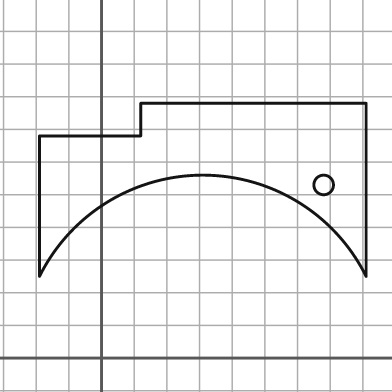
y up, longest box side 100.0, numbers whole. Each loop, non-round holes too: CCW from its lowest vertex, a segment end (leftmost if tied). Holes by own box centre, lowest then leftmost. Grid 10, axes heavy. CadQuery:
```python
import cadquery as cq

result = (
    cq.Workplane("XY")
    .moveTo(-19.0, 25.0)
    .threePointArc((31.0, 56.0), (81.0, 25.0))
    .lineTo(81.0, 78.0)
    .lineTo(12.0, 78.0)
    .lineTo(12.0, 68.0)
    .lineTo(-19.0, 68.0)
    .close()
    .moveTo(68.0, 53.0)
    .circle(3.0)
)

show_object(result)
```